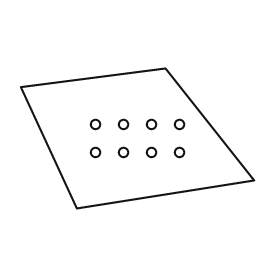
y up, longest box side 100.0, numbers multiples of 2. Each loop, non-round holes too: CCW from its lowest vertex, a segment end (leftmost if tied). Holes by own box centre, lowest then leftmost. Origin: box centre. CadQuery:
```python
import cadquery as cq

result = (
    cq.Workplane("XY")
    .moveTo(-26.0, -30.0)
    .lineTo(50.0, -18.0)
    .lineTo(12.0, 30.0)
    .lineTo(-50.0, 22.0)
    .close()
    .moveTo(-18.0, -6.0)
    .circle(2.0)
    .moveTo(-6.0, -6.0)
    .circle(2.0)
    .moveTo(6.0, -6.0)
    .circle(2.0)
    .moveTo(18.0, -6.0)
    .circle(2.0)
    .moveTo(-18.0, 6.0)
    .circle(2.0)
    .moveTo(-6.0, 6.0)
    .circle(2.0)
    .moveTo(6.0, 6.0)
    .circle(2.0)
    .moveTo(18.0, 6.0)
    .circle(2.0)
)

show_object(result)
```